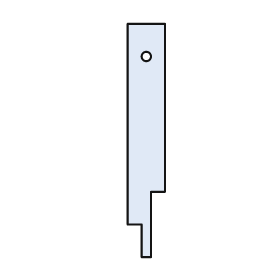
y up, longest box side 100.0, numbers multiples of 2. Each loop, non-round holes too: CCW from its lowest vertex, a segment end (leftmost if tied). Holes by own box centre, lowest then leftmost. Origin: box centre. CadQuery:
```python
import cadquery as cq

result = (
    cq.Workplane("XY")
    .moveTo(-2.0, -50.0)
    .lineTo(2.0, -50.0)
    .lineTo(2.0, -22.0)
    .lineTo(8.0, -22.0)
    .lineTo(8.0, 50.0)
    .lineTo(-8.0, 50.0)
    .lineTo(-8.0, -36.0)
    .lineTo(-2.0, -36.0)
    .close()
    .moveTo(0.0, 36.0)
    .circle(2.0)
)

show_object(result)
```